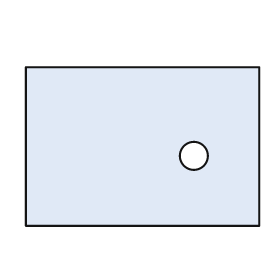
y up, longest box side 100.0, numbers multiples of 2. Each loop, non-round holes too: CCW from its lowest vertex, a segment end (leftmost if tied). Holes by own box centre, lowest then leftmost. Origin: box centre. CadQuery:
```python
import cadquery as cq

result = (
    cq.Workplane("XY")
    .moveTo(-50.0, -34.0)
    .lineTo(50.0, -34.0)
    .lineTo(50.0, 34.0)
    .lineTo(-50.0, 34.0)
    .close()
    .moveTo(22.0, -4.0)
    .circle(6.0)
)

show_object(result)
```